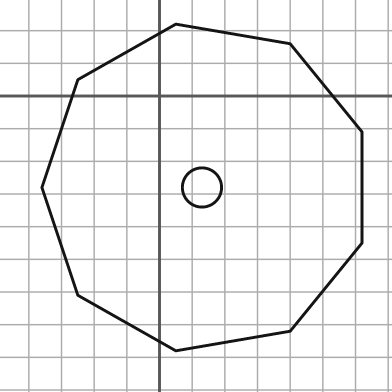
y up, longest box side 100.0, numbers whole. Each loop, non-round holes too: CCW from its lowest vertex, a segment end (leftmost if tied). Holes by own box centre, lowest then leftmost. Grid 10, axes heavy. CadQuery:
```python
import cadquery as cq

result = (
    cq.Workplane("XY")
    .moveTo(5.0, -78.0)
    .lineTo(40.0, -72.0)
    .lineTo(62.0, -45.0)
    .lineTo(62.0, -11.0)
    .lineTo(40.0, 16.0)
    .lineTo(5.0, 22.0)
    .lineTo(-25.0, 5.0)
    .lineTo(-36.0, -28.0)
    .lineTo(-25.0, -61.0)
    .close()
    .moveTo(13.0, -28.0)
    .circle(6.0)
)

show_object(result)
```